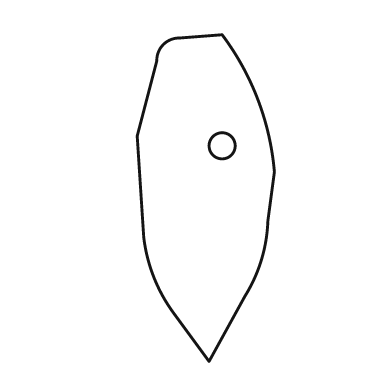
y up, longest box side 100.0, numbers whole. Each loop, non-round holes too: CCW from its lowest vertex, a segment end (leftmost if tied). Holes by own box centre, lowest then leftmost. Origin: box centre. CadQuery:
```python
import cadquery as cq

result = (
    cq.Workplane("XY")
    .moveTo(1.0, -50.0)
    .lineTo(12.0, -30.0)
    .threePointArc((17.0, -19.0), (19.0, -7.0))
    .lineTo(21.0, 8.0)
    .threePointArc((16.0, 30.0), (5.0, 50.0))
    .lineTo(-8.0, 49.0)
    .threePointArc((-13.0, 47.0), (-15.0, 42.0))
    .lineTo(-21.0, 19.0)
    .lineTo(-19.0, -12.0)
    .threePointArc((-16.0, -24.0), (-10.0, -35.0))
    .close()
    .moveTo(5.0, 16.0)
    .circle(4.0)
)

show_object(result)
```